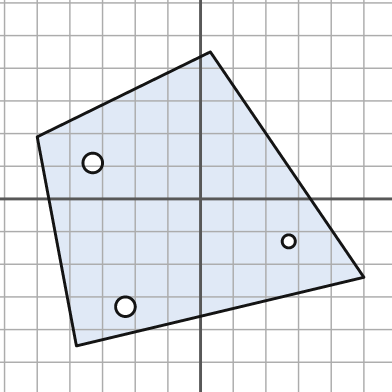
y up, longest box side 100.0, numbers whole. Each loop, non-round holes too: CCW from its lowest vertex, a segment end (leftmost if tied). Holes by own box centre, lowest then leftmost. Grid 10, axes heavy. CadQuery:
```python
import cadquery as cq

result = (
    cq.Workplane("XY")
    .moveTo(-38.0, -45.0)
    .lineTo(50.0, -24.0)
    .lineTo(3.0, 45.0)
    .lineTo(-50.0, 19.0)
    .close()
    .moveTo(-23.0, -33.0)
    .circle(3.0)
    .moveTo(27.0, -13.0)
    .circle(2.0)
    .moveTo(-33.0, 11.0)
    .circle(3.0)
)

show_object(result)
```